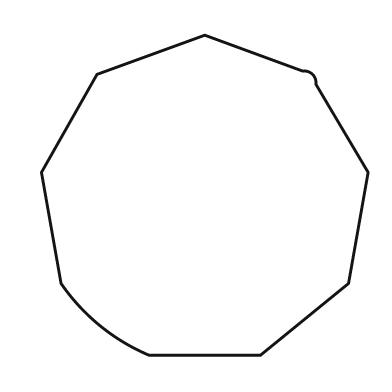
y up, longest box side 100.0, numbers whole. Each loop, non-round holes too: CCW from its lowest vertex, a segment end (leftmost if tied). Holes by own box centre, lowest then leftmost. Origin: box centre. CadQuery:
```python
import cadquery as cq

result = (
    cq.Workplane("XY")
    .moveTo(-17.0, -49.0)
    .lineTo(17.0, -49.0)
    .lineTo(44.0, -27.0)
    .lineTo(50.0, 7.0)
    .lineTo(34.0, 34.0)
    .threePointArc((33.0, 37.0), (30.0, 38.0))
    .lineTo(0.0, 49.0)
    .lineTo(-33.0, 37.0)
    .lineTo(-50.0, 7.0)
    .lineTo(-44.0, -27.0)
    .threePointArc((-32.0, -40.0), (-17.0, -49.0))
    .close()
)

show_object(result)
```